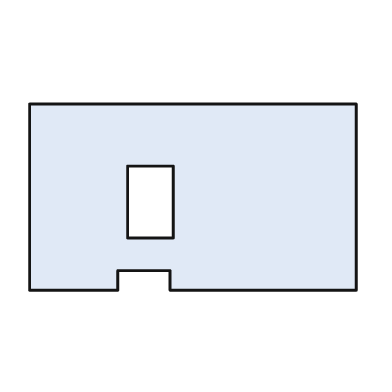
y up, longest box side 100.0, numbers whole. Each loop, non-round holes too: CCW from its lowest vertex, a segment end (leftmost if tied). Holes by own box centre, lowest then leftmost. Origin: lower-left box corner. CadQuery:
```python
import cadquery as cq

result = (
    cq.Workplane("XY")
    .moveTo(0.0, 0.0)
    .lineTo(27.0, 0.0)
    .lineTo(27.0, 6.0)
    .lineTo(43.0, 6.0)
    .lineTo(43.0, 0.0)
    .lineTo(100.0, 0.0)
    .lineTo(100.0, 57.0)
    .lineTo(0.0, 57.0)
    .close()
    .moveTo(30.0, 16.0)
    .lineTo(44.0, 16.0)
    .lineTo(44.0, 38.0)
    .lineTo(30.0, 38.0)
    .close()
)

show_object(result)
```